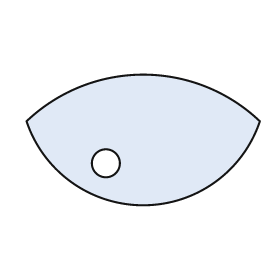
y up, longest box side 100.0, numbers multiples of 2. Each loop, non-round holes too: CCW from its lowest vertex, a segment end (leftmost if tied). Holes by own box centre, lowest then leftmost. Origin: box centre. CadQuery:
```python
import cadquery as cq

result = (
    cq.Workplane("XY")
    .moveTo(-50.0, 8.0)
    .threePointArc((0.0, -28.0), (50.0, 8.0))
    .threePointArc((0.0, 28.0), (-50.0, 8.0))
    .close()
    .moveTo(-16.0, -10.0)
    .circle(6.0)
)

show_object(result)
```